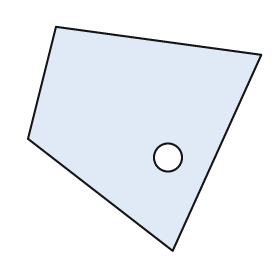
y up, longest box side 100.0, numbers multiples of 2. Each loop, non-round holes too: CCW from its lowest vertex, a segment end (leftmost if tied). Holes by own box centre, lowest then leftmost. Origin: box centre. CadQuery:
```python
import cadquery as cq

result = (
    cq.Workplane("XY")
    .moveTo(12.0, -48.0)
    .lineTo(50.0, 36.0)
    .lineTo(-38.0, 48.0)
    .lineTo(-50.0, 0.0)
    .close()
    .moveTo(10.0, -8.0)
    .circle(6.0)
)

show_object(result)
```